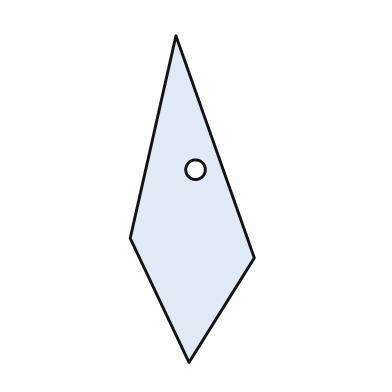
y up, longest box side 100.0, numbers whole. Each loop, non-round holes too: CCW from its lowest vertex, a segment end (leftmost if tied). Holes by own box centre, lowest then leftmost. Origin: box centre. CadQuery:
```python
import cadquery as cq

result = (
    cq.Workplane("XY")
    .moveTo(-1.0, -50.0)
    .lineTo(19.0, -18.0)
    .lineTo(-5.0, 50.0)
    .lineTo(-19.0, -12.0)
    .close()
    .moveTo(1.0, 9.0)
    .circle(3.0)
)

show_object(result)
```